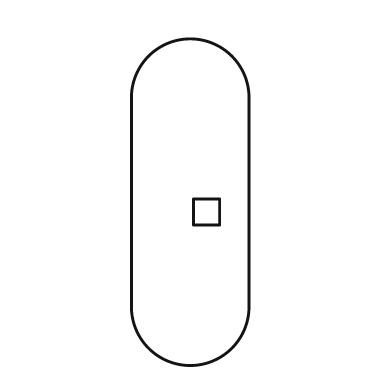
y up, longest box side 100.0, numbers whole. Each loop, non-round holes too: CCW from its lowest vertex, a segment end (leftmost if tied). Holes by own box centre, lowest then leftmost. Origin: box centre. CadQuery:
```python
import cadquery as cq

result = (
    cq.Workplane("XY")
    .moveTo(-18.0, -32.0)
    .threePointArc((0.0, -50.0), (18.0, -32.0))
    .lineTo(18.0, 32.0)
    .threePointArc((0.0, 50.0), (-18.0, 32.0))
    .close()
    .moveTo(1.0, -7.0)
    .lineTo(9.0, -7.0)
    .lineTo(9.0, 1.0)
    .lineTo(1.0, 1.0)
    .close()
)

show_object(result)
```